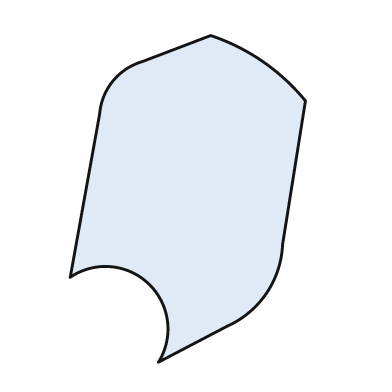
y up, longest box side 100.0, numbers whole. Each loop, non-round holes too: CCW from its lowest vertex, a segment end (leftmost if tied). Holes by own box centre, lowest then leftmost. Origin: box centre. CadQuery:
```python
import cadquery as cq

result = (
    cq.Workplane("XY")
    .moveTo(-9.0, -50.0)
    .lineTo(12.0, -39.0)
    .threePointArc((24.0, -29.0), (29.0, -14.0))
    .lineTo(36.0, 30.0)
    .threePointArc((23.0, 42.0), (7.0, 50.0))
    .lineTo(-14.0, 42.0)
    .threePointArc((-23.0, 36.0), (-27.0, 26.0))
    .lineTo(-36.0, -24.0)
    .threePointArc((-12.0, -26.0), (-9.0, -50.0))
    .close()
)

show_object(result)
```